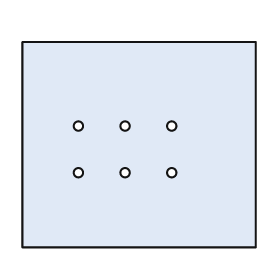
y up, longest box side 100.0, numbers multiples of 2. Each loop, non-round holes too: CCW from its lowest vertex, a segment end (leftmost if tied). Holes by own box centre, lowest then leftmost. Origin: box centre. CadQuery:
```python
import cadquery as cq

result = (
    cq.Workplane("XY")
    .moveTo(-50.0, -44.0)
    .lineTo(50.0, -44.0)
    .lineTo(50.0, 44.0)
    .lineTo(-50.0, 44.0)
    .close()
    .moveTo(-26.0, -12.0)
    .circle(2.0)
    .moveTo(-6.0, -12.0)
    .circle(2.0)
    .moveTo(14.0, -12.0)
    .circle(2.0)
    .moveTo(-26.0, 8.0)
    .circle(2.0)
    .moveTo(-6.0, 8.0)
    .circle(2.0)
    .moveTo(14.0, 8.0)
    .circle(2.0)
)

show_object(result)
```